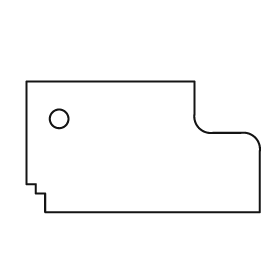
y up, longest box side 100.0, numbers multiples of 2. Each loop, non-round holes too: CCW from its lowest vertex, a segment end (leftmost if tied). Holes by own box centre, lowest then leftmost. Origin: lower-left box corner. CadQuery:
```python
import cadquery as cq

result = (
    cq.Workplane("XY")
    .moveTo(8.0, 0.0)
    .lineTo(100.0, 0.0)
    .lineTo(100.0, 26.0)
    .threePointArc((98.0, 32.0), (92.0, 34.0))
    .lineTo(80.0, 34.0)
    .threePointArc((74.0, 36.0), (72.0, 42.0))
    .lineTo(72.0, 56.0)
    .lineTo(0.0, 56.0)
    .lineTo(0.0, 12.0)
    .lineTo(4.0, 12.0)
    .lineTo(4.0, 8.0)
    .lineTo(8.0, 8.0)
    .close()
    .moveTo(14.0, 40.0)
    .circle(4.0)
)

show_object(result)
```